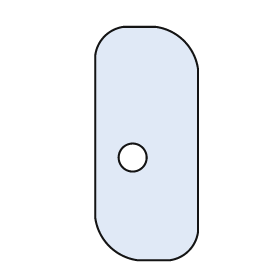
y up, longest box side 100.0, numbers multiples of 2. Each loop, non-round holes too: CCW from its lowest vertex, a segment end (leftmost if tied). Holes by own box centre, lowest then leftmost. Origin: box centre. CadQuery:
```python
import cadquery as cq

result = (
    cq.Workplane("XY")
    .moveTo(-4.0, -50.0)
    .lineTo(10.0, -50.0)
    .threePointArc((18.0, -46.0), (22.0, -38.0))
    .lineTo(22.0, 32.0)
    .threePointArc((16.0, 44.0), (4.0, 50.0))
    .lineTo(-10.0, 50.0)
    .threePointArc((-18.0, 46.0), (-22.0, 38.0))
    .lineTo(-22.0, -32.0)
    .threePointArc((-16.0, -44.0), (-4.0, -50.0))
    .close()
    .moveTo(-6.0, -6.0)
    .circle(6.0)
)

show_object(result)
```